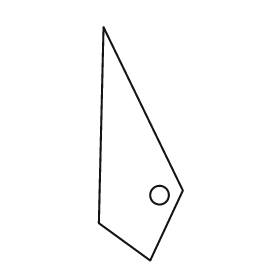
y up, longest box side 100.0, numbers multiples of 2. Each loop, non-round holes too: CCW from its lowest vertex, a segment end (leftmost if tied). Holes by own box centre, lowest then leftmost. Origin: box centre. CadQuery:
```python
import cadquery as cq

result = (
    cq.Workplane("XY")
    .moveTo(4.0, -50.0)
    .lineTo(18.0, -20.0)
    .lineTo(-16.0, 50.0)
    .lineTo(-18.0, -34.0)
    .close()
    .moveTo(8.0, -22.0)
    .circle(4.0)
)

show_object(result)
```